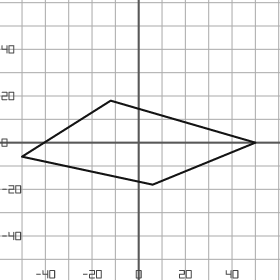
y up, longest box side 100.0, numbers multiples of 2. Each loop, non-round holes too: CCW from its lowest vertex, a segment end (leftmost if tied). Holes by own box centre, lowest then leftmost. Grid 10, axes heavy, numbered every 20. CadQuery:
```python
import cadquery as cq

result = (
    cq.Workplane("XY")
    .moveTo(6.0, -18.0)
    .lineTo(50.0, 0.0)
    .lineTo(-12.0, 18.0)
    .lineTo(-50.0, -6.0)
    .close()
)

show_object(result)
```